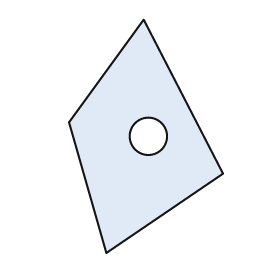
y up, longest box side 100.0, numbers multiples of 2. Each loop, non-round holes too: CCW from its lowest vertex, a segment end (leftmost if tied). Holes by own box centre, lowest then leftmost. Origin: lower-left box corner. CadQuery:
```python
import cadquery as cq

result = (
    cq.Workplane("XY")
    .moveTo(16.0, 0.0)
    .lineTo(66.0, 34.0)
    .lineTo(32.0, 100.0)
    .lineTo(0.0, 56.0)
    .close()
    .moveTo(34.0, 50.0)
    .circle(8.0)
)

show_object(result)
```